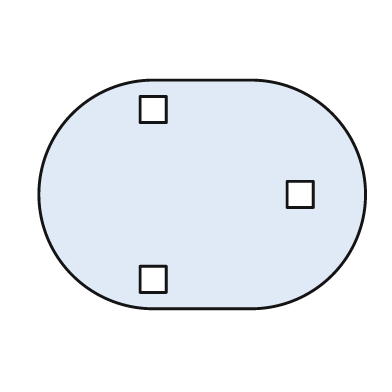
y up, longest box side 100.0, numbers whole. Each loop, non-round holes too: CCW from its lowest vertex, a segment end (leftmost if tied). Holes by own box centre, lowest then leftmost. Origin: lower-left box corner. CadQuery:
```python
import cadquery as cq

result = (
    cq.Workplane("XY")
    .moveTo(35.0, 0.0)
    .lineTo(65.0, 0.0)
    .threePointArc((100.0, 35.0), (65.0, 70.0))
    .lineTo(35.0, 70.0)
    .threePointArc((0.0, 35.0), (35.0, 0.0))
    .close()
    .moveTo(31.0, 5.0)
    .lineTo(39.0, 5.0)
    .lineTo(39.0, 13.0)
    .lineTo(31.0, 13.0)
    .close()
    .moveTo(76.0, 31.0)
    .lineTo(84.0, 31.0)
    .lineTo(84.0, 39.0)
    .lineTo(76.0, 39.0)
    .close()
    .moveTo(31.0, 57.0)
    .lineTo(39.0, 57.0)
    .lineTo(39.0, 65.0)
    .lineTo(31.0, 65.0)
    .close()
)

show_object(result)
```